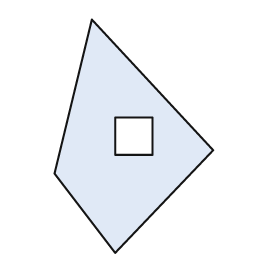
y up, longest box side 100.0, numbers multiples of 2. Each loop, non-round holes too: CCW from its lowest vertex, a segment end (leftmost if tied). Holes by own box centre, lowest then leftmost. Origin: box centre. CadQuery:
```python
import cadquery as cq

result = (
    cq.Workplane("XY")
    .moveTo(-8.0, -50.0)
    .lineTo(34.0, -6.0)
    .lineTo(-18.0, 50.0)
    .lineTo(-34.0, -16.0)
    .close()
    .moveTo(-8.0, -8.0)
    .lineTo(8.0, -8.0)
    .lineTo(8.0, 8.0)
    .lineTo(-8.0, 8.0)
    .close()
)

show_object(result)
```